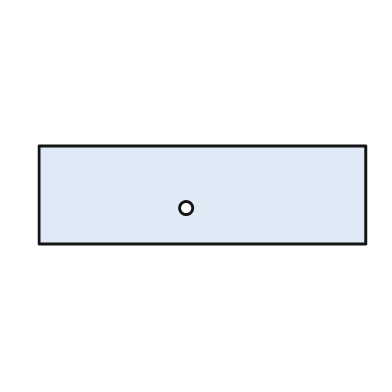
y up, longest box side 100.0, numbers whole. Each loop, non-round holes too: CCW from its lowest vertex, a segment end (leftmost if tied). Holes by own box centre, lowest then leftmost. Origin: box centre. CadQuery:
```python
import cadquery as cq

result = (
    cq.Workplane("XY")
    .moveTo(-50.0, -15.0)
    .lineTo(50.0, -15.0)
    .lineTo(50.0, 15.0)
    .lineTo(-50.0, 15.0)
    .close()
    .moveTo(-5.0, -4.0)
    .circle(2.0)
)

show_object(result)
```